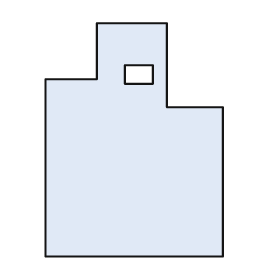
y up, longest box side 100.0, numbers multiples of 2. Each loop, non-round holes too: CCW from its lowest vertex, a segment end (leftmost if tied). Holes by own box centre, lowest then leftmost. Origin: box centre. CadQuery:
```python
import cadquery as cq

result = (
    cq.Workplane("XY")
    .moveTo(-38.0, -50.0)
    .lineTo(38.0, -50.0)
    .lineTo(38.0, 14.0)
    .lineTo(14.0, 14.0)
    .lineTo(14.0, 50.0)
    .lineTo(-16.0, 50.0)
    .lineTo(-16.0, 26.0)
    .lineTo(-38.0, 26.0)
    .close()
    .moveTo(-4.0, 24.0)
    .lineTo(8.0, 24.0)
    .lineTo(8.0, 32.0)
    .lineTo(-4.0, 32.0)
    .close()
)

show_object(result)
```